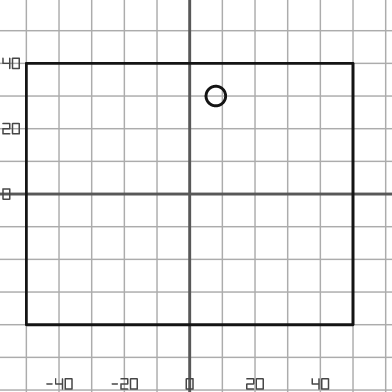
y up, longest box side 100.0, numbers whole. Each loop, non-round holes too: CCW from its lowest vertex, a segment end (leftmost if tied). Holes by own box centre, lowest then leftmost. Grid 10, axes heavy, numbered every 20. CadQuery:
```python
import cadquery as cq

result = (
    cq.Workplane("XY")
    .moveTo(-50.0, -40.0)
    .lineTo(50.0, -40.0)
    .lineTo(50.0, 40.0)
    .lineTo(-50.0, 40.0)
    .close()
    .moveTo(8.0, 30.0)
    .circle(3.0)
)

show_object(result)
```